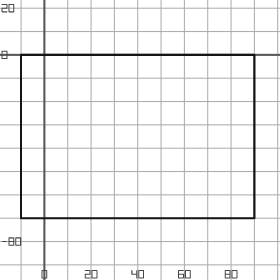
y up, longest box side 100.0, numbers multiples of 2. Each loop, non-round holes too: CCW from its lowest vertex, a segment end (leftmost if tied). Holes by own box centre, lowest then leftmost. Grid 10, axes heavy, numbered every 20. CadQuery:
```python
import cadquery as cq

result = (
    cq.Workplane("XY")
    .moveTo(-10.0, -70.0)
    .lineTo(90.0, -70.0)
    .lineTo(90.0, 0.0)
    .lineTo(-10.0, 0.0)
    .close()
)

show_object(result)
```